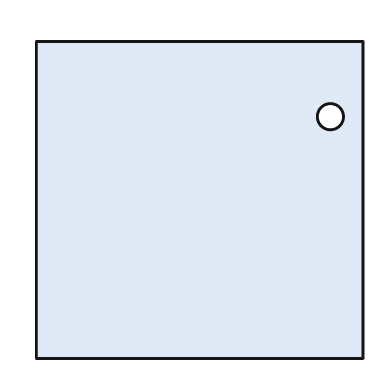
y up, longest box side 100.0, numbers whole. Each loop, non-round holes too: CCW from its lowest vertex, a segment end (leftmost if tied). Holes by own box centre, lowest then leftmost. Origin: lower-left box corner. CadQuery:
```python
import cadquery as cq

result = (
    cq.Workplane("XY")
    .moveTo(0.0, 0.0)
    .lineTo(100.0, 0.0)
    .lineTo(100.0, 97.0)
    .lineTo(0.0, 97.0)
    .close()
    .moveTo(90.0, 74.0)
    .circle(4.0)
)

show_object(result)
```